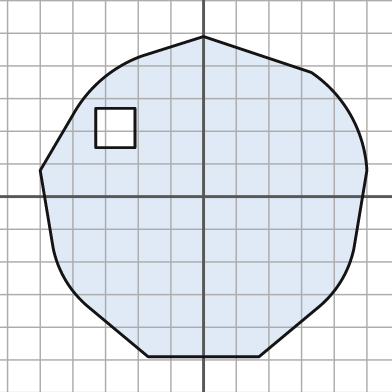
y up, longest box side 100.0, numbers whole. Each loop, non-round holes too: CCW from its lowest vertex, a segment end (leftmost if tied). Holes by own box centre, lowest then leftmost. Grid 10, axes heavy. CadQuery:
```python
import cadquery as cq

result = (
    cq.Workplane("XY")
    .moveTo(-17.0, -49.0)
    .lineTo(17.0, -49.0)
    .lineTo(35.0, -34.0)
    .threePointArc((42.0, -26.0), (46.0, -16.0))
    .lineTo(50.0, 8.0)
    .threePointArc((45.0, 25.0), (33.0, 38.0))
    .lineTo(0.0, 49.0)
    .lineTo(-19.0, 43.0)
    .threePointArc((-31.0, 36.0), (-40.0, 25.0))
    .lineTo(-50.0, 8.0)
    .lineTo(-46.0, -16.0)
    .threePointArc((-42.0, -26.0), (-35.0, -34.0))
    .close()
    .moveTo(-33.0, 15.0)
    .lineTo(-21.0, 15.0)
    .lineTo(-21.0, 27.0)
    .lineTo(-33.0, 27.0)
    .close()
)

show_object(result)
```